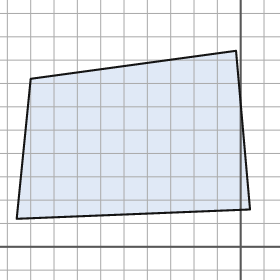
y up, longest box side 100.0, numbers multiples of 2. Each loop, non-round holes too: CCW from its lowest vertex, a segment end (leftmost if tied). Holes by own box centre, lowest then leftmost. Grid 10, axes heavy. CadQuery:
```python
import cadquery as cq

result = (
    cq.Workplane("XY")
    .moveTo(-96.0, 12.0)
    .lineTo(4.0, 16.0)
    .lineTo(-2.0, 84.0)
    .lineTo(-90.0, 72.0)
    .close()
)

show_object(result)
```